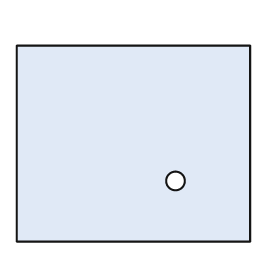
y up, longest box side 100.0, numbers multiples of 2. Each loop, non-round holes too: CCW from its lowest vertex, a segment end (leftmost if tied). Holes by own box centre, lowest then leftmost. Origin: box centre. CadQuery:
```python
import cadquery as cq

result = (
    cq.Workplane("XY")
    .moveTo(-50.0, -42.0)
    .lineTo(50.0, -42.0)
    .lineTo(50.0, 42.0)
    .lineTo(-50.0, 42.0)
    .close()
    .moveTo(18.0, -16.0)
    .circle(4.0)
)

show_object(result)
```